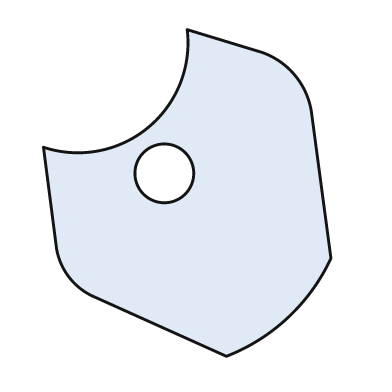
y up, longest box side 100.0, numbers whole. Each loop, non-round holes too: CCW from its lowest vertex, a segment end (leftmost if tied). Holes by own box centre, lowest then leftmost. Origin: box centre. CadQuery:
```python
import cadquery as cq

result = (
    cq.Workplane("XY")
    .moveTo(12.0, -50.0)
    .threePointArc((31.0, -38.0), (44.0, -20.0))
    .lineTo(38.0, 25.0)
    .threePointArc((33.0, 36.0), (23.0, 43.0))
    .lineTo(0.0, 50.0)
    .threePointArc((-12.0, 20.0), (-44.0, 14.0))
    .lineTo(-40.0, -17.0)
    .threePointArc((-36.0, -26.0), (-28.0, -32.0))
    .close()
    .moveTo(-7.0, 6.0)
    .circle(9.0)
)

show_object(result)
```